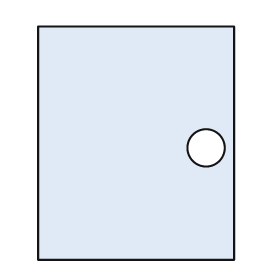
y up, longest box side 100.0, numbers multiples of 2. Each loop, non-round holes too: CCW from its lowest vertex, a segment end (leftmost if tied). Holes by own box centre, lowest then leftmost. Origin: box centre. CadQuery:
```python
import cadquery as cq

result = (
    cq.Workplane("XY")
    .moveTo(-42.0, -50.0)
    .lineTo(42.0, -50.0)
    .lineTo(42.0, 50.0)
    .lineTo(-42.0, 50.0)
    .close()
    .moveTo(30.0, -2.0)
    .circle(8.0)
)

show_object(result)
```